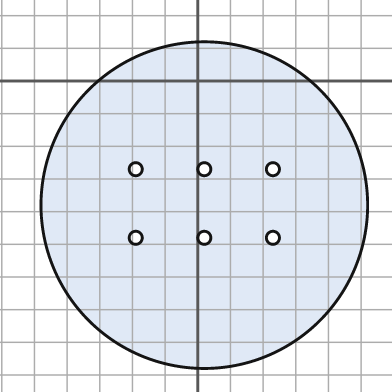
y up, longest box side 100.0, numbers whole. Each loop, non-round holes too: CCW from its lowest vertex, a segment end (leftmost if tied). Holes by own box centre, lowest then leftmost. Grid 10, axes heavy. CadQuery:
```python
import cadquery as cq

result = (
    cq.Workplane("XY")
    .moveTo(2.0, -38.0)
    .circle(50.0)
    .moveTo(-19.0, -48.0)
    .circle(2.0)
    .moveTo(2.0, -48.0)
    .circle(2.0)
    .moveTo(23.0, -48.0)
    .circle(2.0)
    .moveTo(-19.0, -27.0)
    .circle(2.0)
    .moveTo(2.0, -27.0)
    .circle(2.0)
    .moveTo(23.0, -27.0)
    .circle(2.0)
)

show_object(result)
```